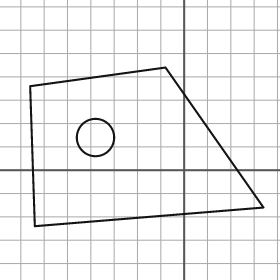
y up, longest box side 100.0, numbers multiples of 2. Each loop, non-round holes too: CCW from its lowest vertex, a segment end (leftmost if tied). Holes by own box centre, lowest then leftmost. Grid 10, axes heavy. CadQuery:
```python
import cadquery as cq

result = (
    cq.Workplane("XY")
    .moveTo(-64.0, -24.0)
    .lineTo(34.0, -16.0)
    .lineTo(-8.0, 44.0)
    .lineTo(-66.0, 36.0)
    .close()
    .moveTo(-38.0, 14.0)
    .circle(8.0)
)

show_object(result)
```